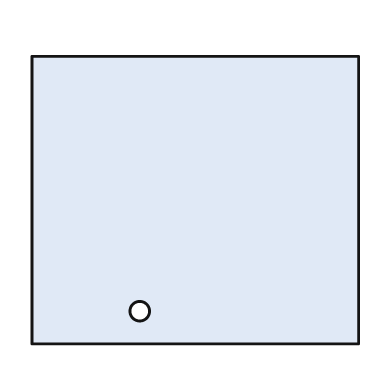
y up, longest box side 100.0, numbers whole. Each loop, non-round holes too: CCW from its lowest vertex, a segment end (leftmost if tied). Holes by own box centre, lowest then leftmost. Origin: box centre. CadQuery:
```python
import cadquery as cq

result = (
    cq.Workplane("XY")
    .moveTo(-50.0, -44.0)
    .lineTo(50.0, -44.0)
    .lineTo(50.0, 44.0)
    .lineTo(-50.0, 44.0)
    .close()
    .moveTo(-17.0, -34.0)
    .circle(3.0)
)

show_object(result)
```